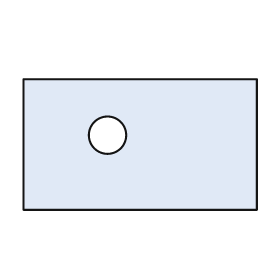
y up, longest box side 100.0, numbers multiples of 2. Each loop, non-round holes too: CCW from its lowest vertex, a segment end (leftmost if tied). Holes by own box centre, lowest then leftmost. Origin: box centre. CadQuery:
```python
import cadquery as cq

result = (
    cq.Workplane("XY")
    .moveTo(-50.0, -28.0)
    .lineTo(50.0, -28.0)
    .lineTo(50.0, 28.0)
    .lineTo(-50.0, 28.0)
    .close()
    .moveTo(-14.0, 4.0)
    .circle(8.0)
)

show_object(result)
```